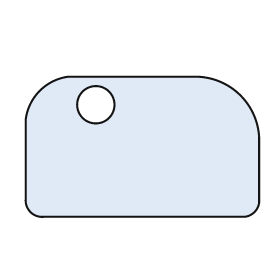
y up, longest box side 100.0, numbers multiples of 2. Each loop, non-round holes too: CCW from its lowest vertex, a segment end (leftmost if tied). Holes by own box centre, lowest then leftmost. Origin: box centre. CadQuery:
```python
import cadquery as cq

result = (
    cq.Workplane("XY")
    .moveTo(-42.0, -30.0)
    .lineTo(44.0, -30.0)
    .threePointArc((48.0, -28.0), (50.0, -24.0))
    .lineTo(50.0, 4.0)
    .threePointArc((42.0, 22.0), (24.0, 30.0))
    .lineTo(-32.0, 30.0)
    .threePointArc((-44.0, 24.0), (-50.0, 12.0))
    .lineTo(-50.0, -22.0)
    .threePointArc((-48.0, -28.0), (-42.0, -30.0))
    .close()
    .moveTo(-20.0, 18.0)
    .circle(8.0)
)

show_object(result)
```